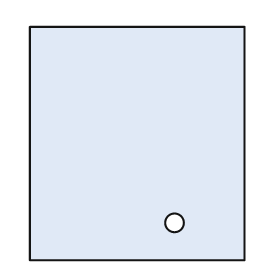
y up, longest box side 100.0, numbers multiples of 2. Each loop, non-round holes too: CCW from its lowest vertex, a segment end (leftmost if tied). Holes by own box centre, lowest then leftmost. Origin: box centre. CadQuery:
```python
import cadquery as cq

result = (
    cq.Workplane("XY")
    .moveTo(-46.0, -50.0)
    .lineTo(46.0, -50.0)
    .lineTo(46.0, 50.0)
    .lineTo(-46.0, 50.0)
    .close()
    .moveTo(16.0, -34.0)
    .circle(4.0)
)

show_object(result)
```